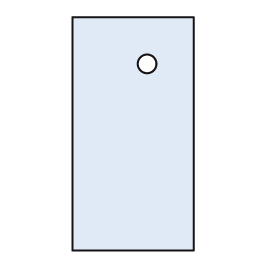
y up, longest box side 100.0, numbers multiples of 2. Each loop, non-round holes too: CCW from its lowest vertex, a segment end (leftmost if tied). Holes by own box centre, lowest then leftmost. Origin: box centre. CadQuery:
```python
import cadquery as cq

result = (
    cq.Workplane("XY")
    .moveTo(-26.0, -50.0)
    .lineTo(26.0, -50.0)
    .lineTo(26.0, 50.0)
    .lineTo(-26.0, 50.0)
    .close()
    .moveTo(6.0, 30.0)
    .circle(4.0)
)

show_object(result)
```